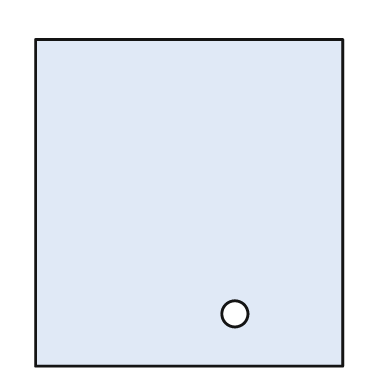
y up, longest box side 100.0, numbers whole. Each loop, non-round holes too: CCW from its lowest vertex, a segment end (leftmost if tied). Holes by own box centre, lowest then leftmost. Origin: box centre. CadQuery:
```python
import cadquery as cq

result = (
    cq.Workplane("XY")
    .moveTo(-47.0, -50.0)
    .lineTo(47.0, -50.0)
    .lineTo(47.0, 50.0)
    .lineTo(-47.0, 50.0)
    .close()
    .moveTo(14.0, -34.0)
    .circle(4.0)
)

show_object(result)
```